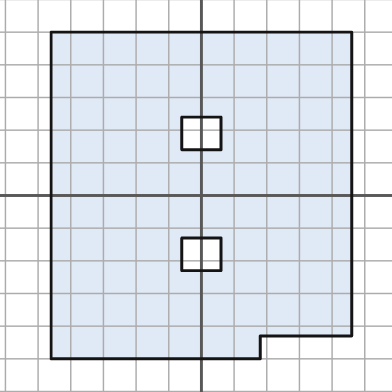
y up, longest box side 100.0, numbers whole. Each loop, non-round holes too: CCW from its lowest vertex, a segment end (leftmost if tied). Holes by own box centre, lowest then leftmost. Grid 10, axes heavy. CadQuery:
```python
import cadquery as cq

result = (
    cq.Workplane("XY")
    .moveTo(-46.0, -50.0)
    .lineTo(18.0, -50.0)
    .lineTo(18.0, -43.0)
    .lineTo(46.0, -43.0)
    .lineTo(46.0, 50.0)
    .lineTo(-46.0, 50.0)
    .close()
    .moveTo(-6.0, -23.0)
    .lineTo(6.0, -23.0)
    .lineTo(6.0, -13.0)
    .lineTo(-6.0, -13.0)
    .close()
    .moveTo(-6.0, 14.0)
    .lineTo(6.0, 14.0)
    .lineTo(6.0, 24.0)
    .lineTo(-6.0, 24.0)
    .close()
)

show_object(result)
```